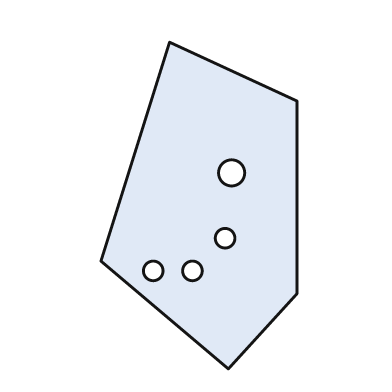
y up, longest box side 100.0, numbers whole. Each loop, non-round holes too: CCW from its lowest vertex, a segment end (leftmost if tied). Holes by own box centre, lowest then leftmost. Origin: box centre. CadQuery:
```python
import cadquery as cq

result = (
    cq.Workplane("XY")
    .moveTo(9.0, -50.0)
    .lineTo(30.0, -27.0)
    .lineTo(30.0, 32.0)
    .lineTo(-9.0, 50.0)
    .lineTo(-30.0, -17.0)
    .close()
    .moveTo(-14.0, -20.0)
    .circle(3.0)
    .moveTo(-2.0, -20.0)
    .circle(3.0)
    .moveTo(8.0, -10.0)
    .circle(3.0)
    .moveTo(10.0, 10.0)
    .circle(4.0)
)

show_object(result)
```